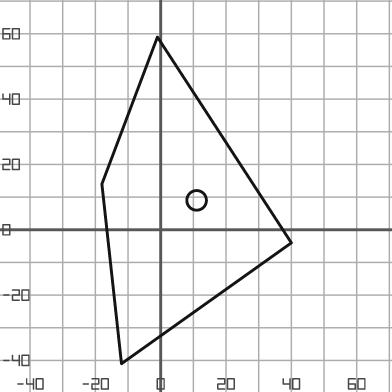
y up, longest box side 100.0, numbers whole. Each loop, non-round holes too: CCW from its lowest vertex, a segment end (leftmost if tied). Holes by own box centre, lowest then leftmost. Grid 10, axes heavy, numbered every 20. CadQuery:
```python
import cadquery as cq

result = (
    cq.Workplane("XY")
    .moveTo(-12.0, -41.0)
    .lineTo(40.0, -4.0)
    .lineTo(-1.0, 59.0)
    .lineTo(-18.0, 14.0)
    .close()
    .moveTo(11.0, 9.0)
    .circle(3.0)
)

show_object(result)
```